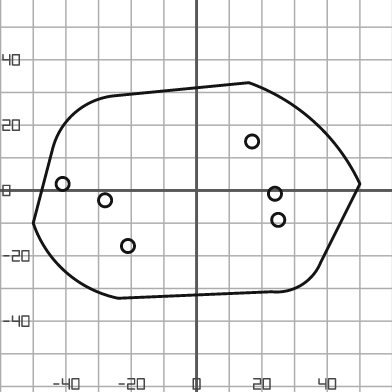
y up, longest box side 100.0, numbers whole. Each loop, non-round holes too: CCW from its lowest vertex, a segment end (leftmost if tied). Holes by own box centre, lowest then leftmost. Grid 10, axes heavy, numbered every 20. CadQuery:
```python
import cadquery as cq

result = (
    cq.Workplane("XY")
    .moveTo(-24.0, -33.0)
    .lineTo(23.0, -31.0)
    .threePointArc((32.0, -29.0), (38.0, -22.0))
    .lineTo(50.0, 2.0)
    .threePointArc((36.0, 21.0), (16.0, 33.0))
    .lineTo(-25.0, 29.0)
    .threePointArc((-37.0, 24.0), (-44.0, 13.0))
    .lineTo(-50.0, -10.0)
    .threePointArc((-40.0, -25.0), (-24.0, -33.0))
    .close()
    .moveTo(-21.0, -17.0)
    .circle(2.0)
    .moveTo(25.0, -9.0)
    .circle(2.0)
    .moveTo(-28.0, -3.0)
    .circle(2.0)
    .moveTo(24.0, -1.0)
    .circle(2.0)
    .moveTo(-41.0, 2.0)
    .circle(2.0)
    .moveTo(17.0, 15.0)
    .circle(2.0)
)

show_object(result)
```